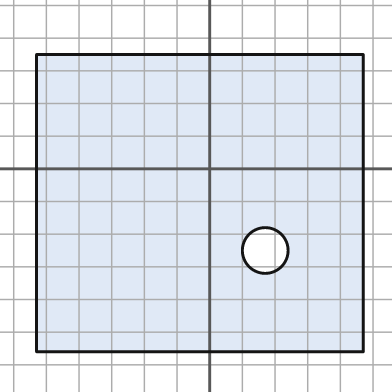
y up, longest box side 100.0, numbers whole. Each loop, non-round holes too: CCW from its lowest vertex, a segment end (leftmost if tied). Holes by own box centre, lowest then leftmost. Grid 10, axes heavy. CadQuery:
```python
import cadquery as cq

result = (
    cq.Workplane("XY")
    .moveTo(-53.0, -56.0)
    .lineTo(47.0, -56.0)
    .lineTo(47.0, 35.0)
    .lineTo(-53.0, 35.0)
    .close()
    .moveTo(17.0, -25.0)
    .circle(7.0)
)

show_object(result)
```